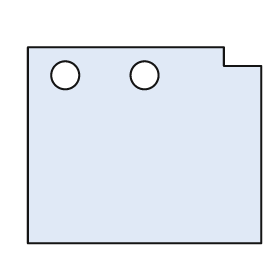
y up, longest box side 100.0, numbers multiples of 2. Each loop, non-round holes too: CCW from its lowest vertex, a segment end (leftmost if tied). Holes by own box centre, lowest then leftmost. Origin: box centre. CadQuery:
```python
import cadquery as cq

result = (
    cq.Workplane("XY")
    .moveTo(-50.0, -42.0)
    .lineTo(50.0, -42.0)
    .lineTo(50.0, 34.0)
    .lineTo(34.0, 34.0)
    .lineTo(34.0, 42.0)
    .lineTo(-50.0, 42.0)
    .close()
    .moveTo(-34.0, 30.0)
    .circle(6.0)
    .moveTo(0.0, 30.0)
    .circle(6.0)
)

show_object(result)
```